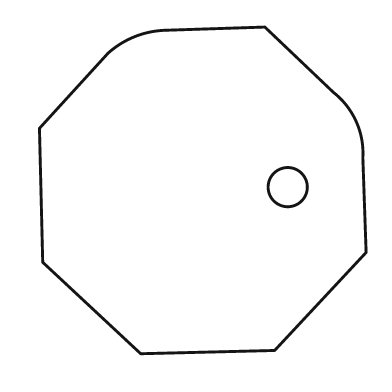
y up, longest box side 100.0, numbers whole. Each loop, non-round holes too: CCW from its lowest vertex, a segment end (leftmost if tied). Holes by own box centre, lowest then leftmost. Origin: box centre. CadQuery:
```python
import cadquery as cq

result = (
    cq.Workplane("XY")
    .moveTo(-19.0, -50.0)
    .lineTo(22.0, -49.0)
    .lineTo(50.0, -19.0)
    .lineTo(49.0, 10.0)
    .threePointArc((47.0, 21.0), (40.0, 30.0))
    .lineTo(19.0, 50.0)
    .lineTo(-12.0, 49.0)
    .threePointArc((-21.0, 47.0), (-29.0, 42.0))
    .lineTo(-50.0, 19.0)
    .lineTo(-49.0, -22.0)
    .close()
    .moveTo(26.0, 1.0)
    .circle(6.0)
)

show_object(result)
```